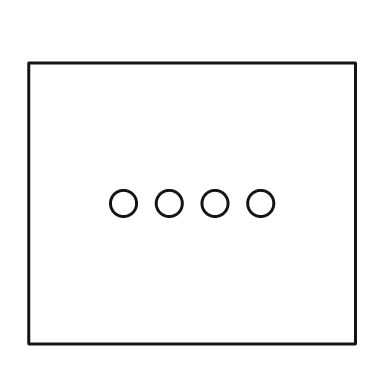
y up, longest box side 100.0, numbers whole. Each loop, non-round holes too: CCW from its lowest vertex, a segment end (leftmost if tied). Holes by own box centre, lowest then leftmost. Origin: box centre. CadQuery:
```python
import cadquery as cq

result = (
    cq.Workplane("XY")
    .moveTo(-50.0, -43.0)
    .lineTo(50.0, -43.0)
    .lineTo(50.0, 43.0)
    .lineTo(-50.0, 43.0)
    .close()
    .moveTo(-21.0, 0.0)
    .circle(4.0)
    .moveTo(-7.0, 0.0)
    .circle(4.0)
    .moveTo(7.0, 0.0)
    .circle(4.0)
    .moveTo(21.0, 0.0)
    .circle(4.0)
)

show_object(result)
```